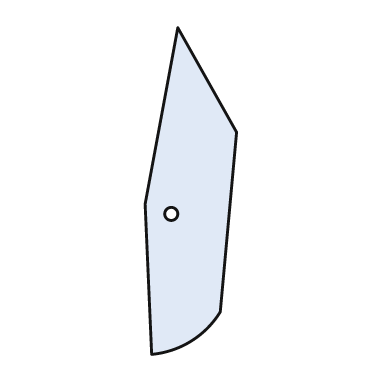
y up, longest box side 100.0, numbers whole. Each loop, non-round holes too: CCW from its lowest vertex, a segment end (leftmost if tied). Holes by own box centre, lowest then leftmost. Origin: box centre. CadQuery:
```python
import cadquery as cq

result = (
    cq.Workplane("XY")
    .moveTo(-12.0, -50.0)
    .threePointArc((0.0, -46.0), (9.0, -37.0))
    .lineTo(14.0, 18.0)
    .lineTo(-4.0, 50.0)
    .lineTo(-14.0, -4.0)
    .close()
    .moveTo(-6.0, -7.0)
    .circle(2.0)
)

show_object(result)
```